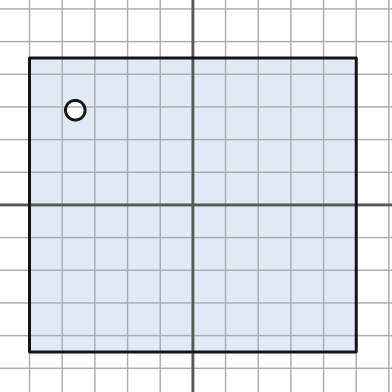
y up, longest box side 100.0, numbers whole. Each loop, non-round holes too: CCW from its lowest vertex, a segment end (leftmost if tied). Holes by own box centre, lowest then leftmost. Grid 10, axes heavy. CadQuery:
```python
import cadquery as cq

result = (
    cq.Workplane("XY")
    .moveTo(-50.0, -45.0)
    .lineTo(50.0, -45.0)
    .lineTo(50.0, 45.0)
    .lineTo(-50.0, 45.0)
    .close()
    .moveTo(-36.0, 29.0)
    .circle(3.0)
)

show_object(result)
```